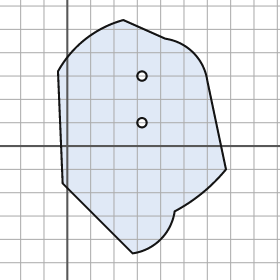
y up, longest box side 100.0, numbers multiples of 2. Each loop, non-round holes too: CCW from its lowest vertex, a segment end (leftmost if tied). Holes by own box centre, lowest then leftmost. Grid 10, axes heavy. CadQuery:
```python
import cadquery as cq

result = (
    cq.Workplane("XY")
    .moveTo(28.0, -46.0)
    .threePointArc((40.0, -40.0), (46.0, -28.0))
    .threePointArc((58.0, -20.0), (68.0, -10.0))
    .lineTo(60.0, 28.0)
    .threePointArc((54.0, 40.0), (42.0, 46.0))
    .lineTo(24.0, 54.0)
    .threePointArc((8.0, 46.0), (-4.0, 32.0))
    .lineTo(-2.0, -16.0)
    .close()
    .moveTo(32.0, 10.0)
    .circle(2.0)
    .moveTo(32.0, 30.0)
    .circle(2.0)
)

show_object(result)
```